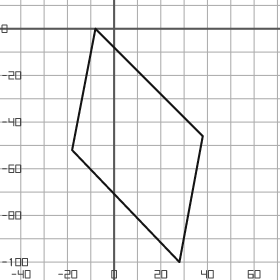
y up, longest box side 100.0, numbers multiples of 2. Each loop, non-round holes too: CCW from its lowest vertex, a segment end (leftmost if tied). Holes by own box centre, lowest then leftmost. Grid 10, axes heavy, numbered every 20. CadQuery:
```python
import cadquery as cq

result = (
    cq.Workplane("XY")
    .moveTo(28.0, -100.0)
    .lineTo(38.0, -46.0)
    .lineTo(-8.0, 0.0)
    .lineTo(-18.0, -52.0)
    .close()
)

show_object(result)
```